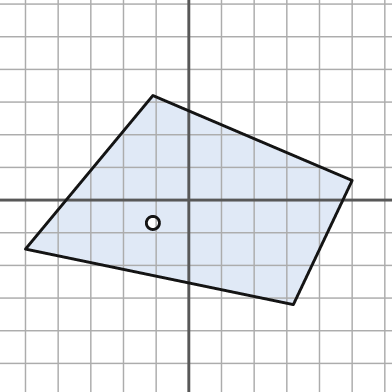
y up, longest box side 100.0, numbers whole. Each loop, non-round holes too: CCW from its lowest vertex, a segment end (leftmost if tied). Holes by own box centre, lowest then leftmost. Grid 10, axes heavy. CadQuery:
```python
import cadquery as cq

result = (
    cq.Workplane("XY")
    .moveTo(32.0, -32.0)
    .lineTo(50.0, 6.0)
    .lineTo(-11.0, 32.0)
    .lineTo(-50.0, -15.0)
    .close()
    .moveTo(-11.0, -7.0)
    .circle(2.0)
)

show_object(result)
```